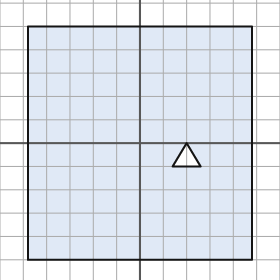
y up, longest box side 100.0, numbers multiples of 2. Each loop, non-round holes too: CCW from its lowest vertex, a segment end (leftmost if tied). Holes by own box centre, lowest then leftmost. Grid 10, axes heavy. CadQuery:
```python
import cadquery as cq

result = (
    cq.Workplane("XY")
    .moveTo(-48.0, -50.0)
    .lineTo(48.0, -50.0)
    .lineTo(48.0, 50.0)
    .lineTo(-48.0, 50.0)
    .close()
    .moveTo(14.0, -10.0)
    .lineTo(26.0, -10.0)
    .lineTo(20.0, 0.0)
    .close()
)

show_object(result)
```